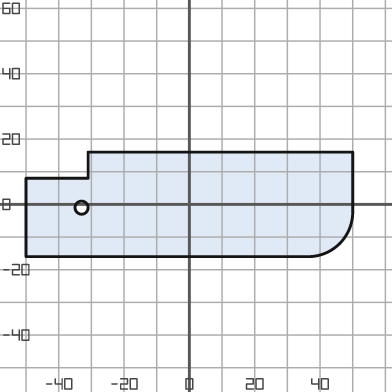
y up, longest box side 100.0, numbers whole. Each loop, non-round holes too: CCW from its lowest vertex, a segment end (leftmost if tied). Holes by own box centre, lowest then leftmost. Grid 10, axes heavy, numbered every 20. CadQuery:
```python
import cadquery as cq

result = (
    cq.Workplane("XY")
    .moveTo(-50.0, -16.0)
    .lineTo(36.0, -16.0)
    .threePointArc((46.0, -12.0), (50.0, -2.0))
    .lineTo(50.0, 16.0)
    .lineTo(-31.0, 16.0)
    .lineTo(-31.0, 8.0)
    .lineTo(-50.0, 8.0)
    .close()
    .moveTo(-33.0, -1.0)
    .circle(2.0)
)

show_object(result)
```